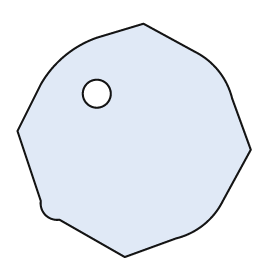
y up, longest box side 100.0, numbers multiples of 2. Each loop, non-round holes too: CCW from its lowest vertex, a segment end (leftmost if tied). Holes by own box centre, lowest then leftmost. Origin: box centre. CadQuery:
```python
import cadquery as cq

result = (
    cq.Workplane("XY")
    .moveTo(-4.0, -50.0)
    .lineTo(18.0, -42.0)
    .threePointArc((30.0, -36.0), (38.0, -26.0))
    .lineTo(50.0, -4.0)
    .lineTo(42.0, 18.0)
    .threePointArc((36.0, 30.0), (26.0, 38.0))
    .lineTo(4.0, 50.0)
    .lineTo(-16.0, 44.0)
    .threePointArc((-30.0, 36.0), (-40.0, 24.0))
    .lineTo(-50.0, 4.0)
    .lineTo(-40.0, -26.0)
    .threePointArc((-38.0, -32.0), (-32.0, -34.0))
    .close()
    .moveTo(-16.0, 20.0)
    .circle(6.0)
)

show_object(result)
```